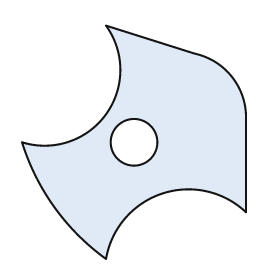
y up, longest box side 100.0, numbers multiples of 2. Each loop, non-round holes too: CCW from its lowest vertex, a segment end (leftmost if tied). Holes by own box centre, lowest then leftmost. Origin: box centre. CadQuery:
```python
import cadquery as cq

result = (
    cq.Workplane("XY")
    .moveTo(-12.0, -50.0)
    .threePointArc((12.0, -22.0), (48.0, -30.0))
    .lineTo(48.0, 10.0)
    .threePointArc((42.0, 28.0), (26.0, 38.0))
    .lineTo(-12.0, 50.0)
    .threePointArc((-12.0, 12.0), (-48.0, 0.0))
    .threePointArc((-34.0, -28.0), (-12.0, -50.0))
    .close()
    .moveTo(0.0, 0.0)
    .circle(10.0)
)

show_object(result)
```